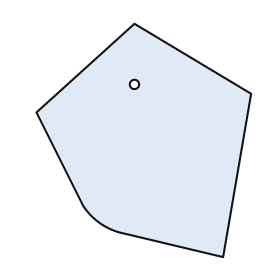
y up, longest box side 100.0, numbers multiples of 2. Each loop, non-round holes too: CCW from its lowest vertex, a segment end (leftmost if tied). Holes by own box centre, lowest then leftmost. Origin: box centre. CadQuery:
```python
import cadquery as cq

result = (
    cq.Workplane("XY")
    .moveTo(34.0, -50.0)
    .lineTo(46.0, 20.0)
    .lineTo(-4.0, 50.0)
    .lineTo(-46.0, 12.0)
    .lineTo(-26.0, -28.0)
    .threePointArc((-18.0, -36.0), (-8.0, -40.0))
    .close()
    .moveTo(-4.0, 24.0)
    .circle(2.0)
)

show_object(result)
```